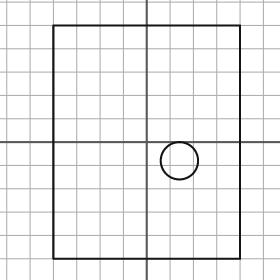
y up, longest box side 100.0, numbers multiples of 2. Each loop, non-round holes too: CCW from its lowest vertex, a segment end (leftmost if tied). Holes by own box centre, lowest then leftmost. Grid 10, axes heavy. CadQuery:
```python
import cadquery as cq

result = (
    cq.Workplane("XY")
    .moveTo(-40.0, -50.0)
    .lineTo(40.0, -50.0)
    .lineTo(40.0, 50.0)
    .lineTo(-40.0, 50.0)
    .close()
    .moveTo(14.0, -8.0)
    .circle(8.0)
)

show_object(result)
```